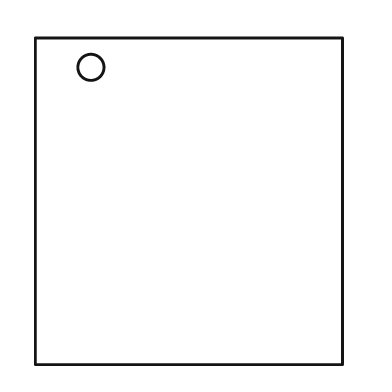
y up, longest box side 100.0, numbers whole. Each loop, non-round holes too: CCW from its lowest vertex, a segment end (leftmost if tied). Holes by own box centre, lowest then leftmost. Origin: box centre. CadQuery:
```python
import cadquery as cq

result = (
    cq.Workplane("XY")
    .moveTo(-47.0, -50.0)
    .lineTo(47.0, -50.0)
    .lineTo(47.0, 50.0)
    .lineTo(-47.0, 50.0)
    .close()
    .moveTo(-30.0, 41.0)
    .circle(4.0)
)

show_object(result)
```